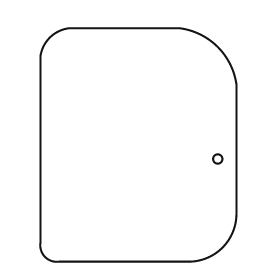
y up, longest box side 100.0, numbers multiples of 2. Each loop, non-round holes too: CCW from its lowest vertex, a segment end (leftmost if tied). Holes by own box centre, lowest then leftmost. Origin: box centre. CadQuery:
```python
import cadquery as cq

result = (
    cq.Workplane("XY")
    .moveTo(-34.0, -50.0)
    .lineTo(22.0, -50.0)
    .threePointArc((36.0, -44.0), (42.0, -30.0))
    .lineTo(42.0, 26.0)
    .threePointArc((34.0, 42.0), (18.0, 50.0))
    .lineTo(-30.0, 50.0)
    .threePointArc((-38.0, 46.0), (-42.0, 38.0))
    .lineTo(-42.0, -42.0)
    .threePointArc((-40.0, -48.0), (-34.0, -50.0))
    .close()
    .moveTo(34.0, -6.0)
    .circle(2.0)
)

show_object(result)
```